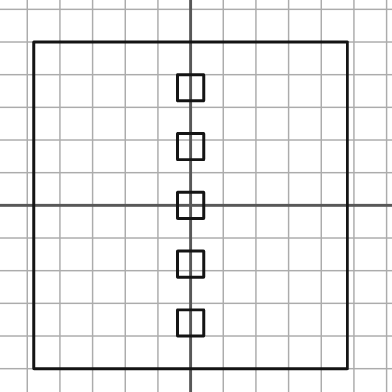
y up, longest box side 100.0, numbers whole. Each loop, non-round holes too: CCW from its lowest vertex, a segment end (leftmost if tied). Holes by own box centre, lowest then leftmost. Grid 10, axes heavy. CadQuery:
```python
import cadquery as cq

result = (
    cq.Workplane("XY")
    .moveTo(-48.0, -50.0)
    .lineTo(48.0, -50.0)
    .lineTo(48.0, 50.0)
    .lineTo(-48.0, 50.0)
    .close()
    .moveTo(-4.0, -40.0)
    .lineTo(4.0, -40.0)
    .lineTo(4.0, -32.0)
    .lineTo(-4.0, -32.0)
    .close()
    .moveTo(-4.0, -22.0)
    .lineTo(4.0, -22.0)
    .lineTo(4.0, -14.0)
    .lineTo(-4.0, -14.0)
    .close()
    .moveTo(-4.0, -4.0)
    .lineTo(4.0, -4.0)
    .lineTo(4.0, 4.0)
    .lineTo(-4.0, 4.0)
    .close()
    .moveTo(-4.0, 14.0)
    .lineTo(4.0, 14.0)
    .lineTo(4.0, 22.0)
    .lineTo(-4.0, 22.0)
    .close()
    .moveTo(-4.0, 32.0)
    .lineTo(4.0, 32.0)
    .lineTo(4.0, 40.0)
    .lineTo(-4.0, 40.0)
    .close()
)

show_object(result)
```